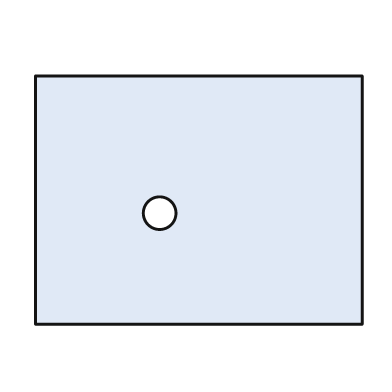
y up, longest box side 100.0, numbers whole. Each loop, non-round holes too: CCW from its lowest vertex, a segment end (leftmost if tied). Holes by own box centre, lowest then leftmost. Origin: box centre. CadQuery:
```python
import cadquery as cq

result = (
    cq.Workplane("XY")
    .moveTo(-50.0, -38.0)
    .lineTo(50.0, -38.0)
    .lineTo(50.0, 38.0)
    .lineTo(-50.0, 38.0)
    .close()
    .moveTo(-12.0, -4.0)
    .circle(5.0)
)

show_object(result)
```